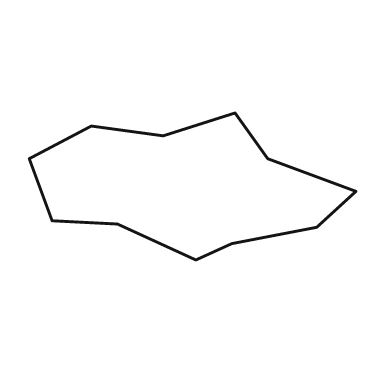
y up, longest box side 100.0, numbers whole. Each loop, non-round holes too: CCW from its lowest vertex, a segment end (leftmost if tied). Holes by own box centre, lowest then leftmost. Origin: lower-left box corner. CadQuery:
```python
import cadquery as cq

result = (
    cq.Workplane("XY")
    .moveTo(51.0, 0.0)
    .lineTo(62.0, 5.0)
    .lineTo(88.0, 10.0)
    .lineTo(100.0, 21.0)
    .lineTo(73.0, 31.0)
    .lineTo(63.0, 45.0)
    .lineTo(41.0, 38.0)
    .lineTo(19.0, 41.0)
    .lineTo(0.0, 31.0)
    .lineTo(7.0, 12.0)
    .lineTo(27.0, 11.0)
    .close()
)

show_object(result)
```